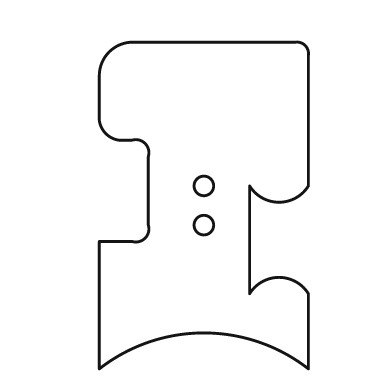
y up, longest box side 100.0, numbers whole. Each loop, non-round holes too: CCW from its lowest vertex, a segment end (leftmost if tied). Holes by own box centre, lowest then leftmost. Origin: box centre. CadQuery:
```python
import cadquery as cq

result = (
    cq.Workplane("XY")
    .moveTo(-32.0, -50.0)
    .threePointArc((0.0, -39.0), (32.0, -50.0))
    .lineTo(32.0, -27.0)
    .threePointArc((23.0, -22.0), (14.0, -27.0))
    .lineTo(14.0, 6.0)
    .threePointArc((23.0, 1.0), (32.0, 6.0))
    .lineTo(32.0, 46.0)
    .threePointArc((31.0, 49.0), (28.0, 50.0))
    .lineTo(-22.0, 50.0)
    .threePointArc((-29.0, 47.0), (-32.0, 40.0))
    .lineTo(-32.0, 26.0)
    .threePointArc((-30.0, 22.0), (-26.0, 20.0))
    .lineTo(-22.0, 20.0)
    .threePointArc((-18.0, 19.0), (-17.0, 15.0))
    .lineTo(-17.0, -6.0)
    .threePointArc((-18.0, -10.0), (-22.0, -11.0))
    .lineTo(-32.0, -11.0)
    .close()
    .moveTo(0.0, -6.0)
    .circle(3.0)
    .moveTo(0.0, 6.0)
    .circle(3.0)
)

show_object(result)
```